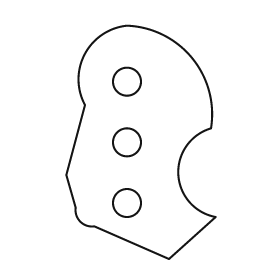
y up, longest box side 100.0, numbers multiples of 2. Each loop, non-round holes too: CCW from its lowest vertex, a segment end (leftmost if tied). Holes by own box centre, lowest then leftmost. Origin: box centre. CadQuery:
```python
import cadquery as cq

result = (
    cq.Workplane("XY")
    .moveTo(12.0, -50.0)
    .lineTo(32.0, -32.0)
    .threePointArc((16.0, -14.0), (30.0, 6.0))
    .threePointArc((22.0, 36.0), (-6.0, 50.0))
    .threePointArc((-24.0, 38.0), (-24.0, 16.0))
    .lineTo(-32.0, -14.0)
    .lineTo(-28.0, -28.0)
    .threePointArc((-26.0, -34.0), (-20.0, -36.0))
    .close()
    .moveTo(-6.0, -26.0)
    .circle(6.0)
    .moveTo(-6.0, 0.0)
    .circle(6.0)
    .moveTo(-6.0, 26.0)
    .circle(6.0)
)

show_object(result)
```